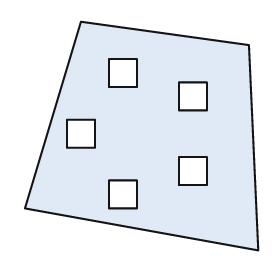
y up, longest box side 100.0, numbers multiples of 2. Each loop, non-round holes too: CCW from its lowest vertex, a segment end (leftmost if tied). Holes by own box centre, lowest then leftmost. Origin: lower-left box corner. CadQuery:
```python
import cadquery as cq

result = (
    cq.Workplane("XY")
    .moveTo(100.0, 0.0)
    .lineTo(96.0, 88.0)
    .lineTo(24.0, 98.0)
    .lineTo(0.0, 18.0)
    .close()
    .moveTo(36.0, 18.0)
    .lineTo(48.0, 18.0)
    .lineTo(48.0, 30.0)
    .lineTo(36.0, 30.0)
    .close()
    .moveTo(66.0, 28.0)
    .lineTo(78.0, 28.0)
    .lineTo(78.0, 40.0)
    .lineTo(66.0, 40.0)
    .close()
    .moveTo(18.0, 44.0)
    .lineTo(30.0, 44.0)
    .lineTo(30.0, 56.0)
    .lineTo(18.0, 56.0)
    .close()
    .moveTo(66.0, 60.0)
    .lineTo(78.0, 60.0)
    .lineTo(78.0, 72.0)
    .lineTo(66.0, 72.0)
    .close()
    .moveTo(36.0, 70.0)
    .lineTo(48.0, 70.0)
    .lineTo(48.0, 82.0)
    .lineTo(36.0, 82.0)
    .close()
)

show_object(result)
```